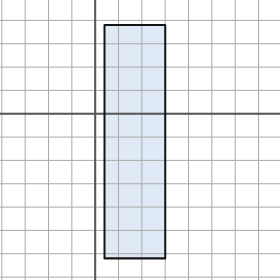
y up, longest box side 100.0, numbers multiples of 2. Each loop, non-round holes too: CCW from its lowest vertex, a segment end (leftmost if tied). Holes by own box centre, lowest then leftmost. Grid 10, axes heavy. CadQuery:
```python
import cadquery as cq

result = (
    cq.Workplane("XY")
    .moveTo(4.0, -62.0)
    .lineTo(30.0, -62.0)
    .lineTo(30.0, 38.0)
    .lineTo(4.0, 38.0)
    .close()
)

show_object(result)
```